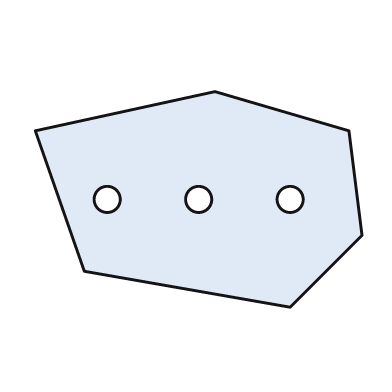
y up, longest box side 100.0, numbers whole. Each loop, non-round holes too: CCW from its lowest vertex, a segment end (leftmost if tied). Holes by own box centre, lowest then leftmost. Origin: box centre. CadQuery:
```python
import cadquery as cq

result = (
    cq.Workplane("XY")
    .moveTo(28.0, -33.0)
    .lineTo(50.0, -11.0)
    .lineTo(46.0, 21.0)
    .lineTo(5.0, 33.0)
    .lineTo(-50.0, 21.0)
    .lineTo(-35.0, -22.0)
    .close()
    .moveTo(-28.0, 0.0)
    .circle(4.0)
    .moveTo(0.0, 0.0)
    .circle(4.0)
    .moveTo(28.0, 0.0)
    .circle(4.0)
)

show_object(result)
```